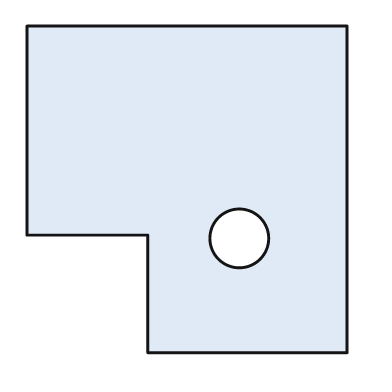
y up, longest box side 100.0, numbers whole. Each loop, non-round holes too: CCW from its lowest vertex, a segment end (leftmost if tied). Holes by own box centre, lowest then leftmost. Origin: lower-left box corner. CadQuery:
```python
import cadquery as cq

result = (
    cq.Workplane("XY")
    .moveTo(37.0, 0.0)
    .lineTo(98.0, 0.0)
    .lineTo(98.0, 100.0)
    .lineTo(0.0, 100.0)
    .lineTo(0.0, 36.0)
    .lineTo(37.0, 36.0)
    .close()
    .moveTo(65.0, 35.0)
    .circle(9.0)
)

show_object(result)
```